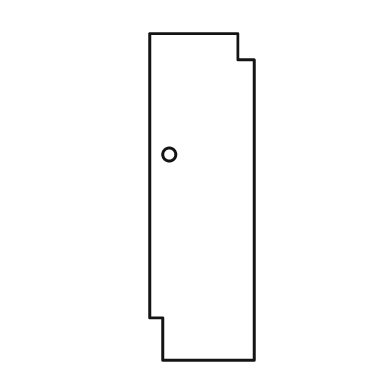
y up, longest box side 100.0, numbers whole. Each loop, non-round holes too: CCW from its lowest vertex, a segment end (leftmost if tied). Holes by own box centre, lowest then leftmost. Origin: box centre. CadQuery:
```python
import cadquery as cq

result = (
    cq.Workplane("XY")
    .moveTo(-12.0, -50.0)
    .lineTo(16.0, -50.0)
    .lineTo(16.0, 42.0)
    .lineTo(11.0, 42.0)
    .lineTo(11.0, 50.0)
    .lineTo(-16.0, 50.0)
    .lineTo(-16.0, -37.0)
    .lineTo(-12.0, -37.0)
    .close()
    .moveTo(-10.0, 13.0)
    .circle(2.0)
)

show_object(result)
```